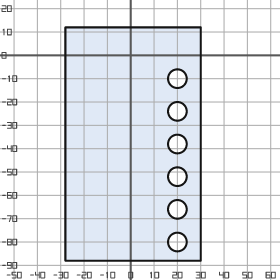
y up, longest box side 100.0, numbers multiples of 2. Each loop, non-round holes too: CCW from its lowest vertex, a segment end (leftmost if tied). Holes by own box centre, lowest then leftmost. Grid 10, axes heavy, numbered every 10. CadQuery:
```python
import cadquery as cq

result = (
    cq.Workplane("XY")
    .moveTo(-28.0, -88.0)
    .lineTo(30.0, -88.0)
    .lineTo(30.0, 12.0)
    .lineTo(-28.0, 12.0)
    .close()
    .moveTo(20.0, -80.0)
    .circle(4.0)
    .moveTo(20.0, -66.0)
    .circle(4.0)
    .moveTo(20.0, -52.0)
    .circle(4.0)
    .moveTo(20.0, -38.0)
    .circle(4.0)
    .moveTo(20.0, -24.0)
    .circle(4.0)
    .moveTo(20.0, -10.0)
    .circle(4.0)
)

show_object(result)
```